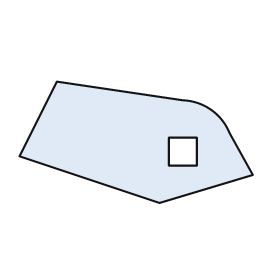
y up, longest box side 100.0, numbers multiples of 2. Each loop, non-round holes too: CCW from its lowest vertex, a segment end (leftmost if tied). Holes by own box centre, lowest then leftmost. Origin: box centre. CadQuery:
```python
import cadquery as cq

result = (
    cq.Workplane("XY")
    .moveTo(10.0, -26.0)
    .lineTo(50.0, -14.0)
    .lineTo(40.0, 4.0)
    .threePointArc((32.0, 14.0), (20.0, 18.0))
    .lineTo(-34.0, 26.0)
    .lineTo(-50.0, -6.0)
    .close()
    .moveTo(14.0, -10.0)
    .lineTo(26.0, -10.0)
    .lineTo(26.0, 2.0)
    .lineTo(14.0, 2.0)
    .close()
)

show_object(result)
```